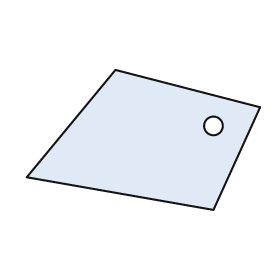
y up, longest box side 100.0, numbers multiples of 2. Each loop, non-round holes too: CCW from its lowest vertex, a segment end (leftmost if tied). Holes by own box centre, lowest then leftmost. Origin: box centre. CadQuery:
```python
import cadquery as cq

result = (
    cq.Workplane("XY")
    .moveTo(30.0, -30.0)
    .lineTo(50.0, 14.0)
    .lineTo(-12.0, 30.0)
    .lineTo(-50.0, -16.0)
    .close()
    .moveTo(30.0, 6.0)
    .circle(4.0)
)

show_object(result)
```